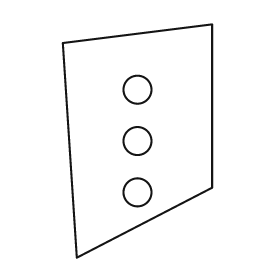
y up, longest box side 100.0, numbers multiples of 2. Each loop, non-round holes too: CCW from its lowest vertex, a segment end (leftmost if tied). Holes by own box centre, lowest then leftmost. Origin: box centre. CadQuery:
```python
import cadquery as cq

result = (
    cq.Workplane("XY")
    .moveTo(-26.0, -50.0)
    .lineTo(32.0, -20.0)
    .lineTo(32.0, 50.0)
    .lineTo(-32.0, 42.0)
    .close()
    .moveTo(0.0, -22.0)
    .circle(6.0)
    .moveTo(0.0, 0.0)
    .circle(6.0)
    .moveTo(0.0, 22.0)
    .circle(6.0)
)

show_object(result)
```